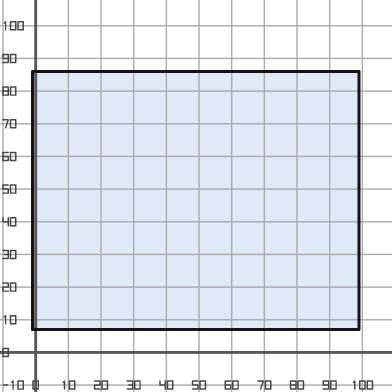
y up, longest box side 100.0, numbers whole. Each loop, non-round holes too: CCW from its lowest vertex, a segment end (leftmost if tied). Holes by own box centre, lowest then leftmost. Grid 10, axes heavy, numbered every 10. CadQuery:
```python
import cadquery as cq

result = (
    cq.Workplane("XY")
    .moveTo(-1.0, 7.0)
    .lineTo(99.0, 7.0)
    .lineTo(99.0, 86.0)
    .lineTo(-1.0, 86.0)
    .close()
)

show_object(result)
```